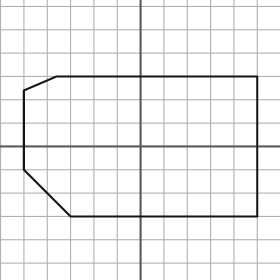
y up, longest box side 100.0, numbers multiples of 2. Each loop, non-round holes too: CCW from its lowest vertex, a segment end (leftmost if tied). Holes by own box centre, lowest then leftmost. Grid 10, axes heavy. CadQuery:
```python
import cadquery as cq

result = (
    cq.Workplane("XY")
    .moveTo(-30.0, -30.0)
    .lineTo(50.0, -30.0)
    .lineTo(50.0, 30.0)
    .lineTo(-36.0, 30.0)
    .lineTo(-50.0, 24.0)
    .lineTo(-50.0, -10.0)
    .close()
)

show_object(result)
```